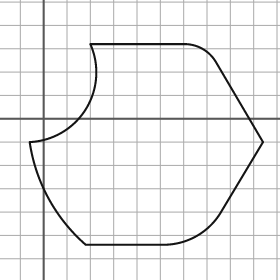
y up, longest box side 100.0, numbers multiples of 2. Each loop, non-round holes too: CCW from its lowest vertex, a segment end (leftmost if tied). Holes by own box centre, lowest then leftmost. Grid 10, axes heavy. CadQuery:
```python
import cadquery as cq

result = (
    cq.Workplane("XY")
    .moveTo(18.0, -54.0)
    .lineTo(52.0, -54.0)
    .threePointArc((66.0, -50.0), (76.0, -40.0))
    .lineTo(94.0, -10.0)
    .lineTo(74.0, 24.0)
    .threePointArc((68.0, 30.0), (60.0, 32.0))
    .lineTo(20.0, 32.0)
    .threePointArc((18.0, 4.0), (-6.0, -10.0))
    .threePointArc((2.0, -34.0), (18.0, -54.0))
    .close()
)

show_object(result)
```